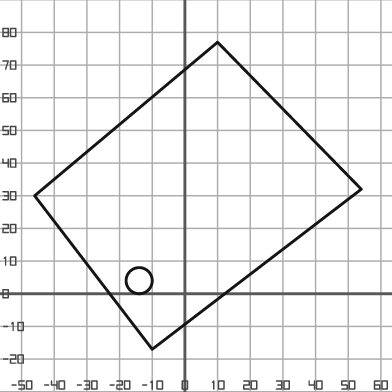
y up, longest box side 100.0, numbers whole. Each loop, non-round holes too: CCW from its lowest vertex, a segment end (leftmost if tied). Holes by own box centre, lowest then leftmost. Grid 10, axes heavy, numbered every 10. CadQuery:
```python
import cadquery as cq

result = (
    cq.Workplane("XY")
    .moveTo(-10.0, -17.0)
    .lineTo(54.0, 32.0)
    .lineTo(10.0, 77.0)
    .lineTo(-46.0, 30.0)
    .close()
    .moveTo(-14.0, 4.0)
    .circle(4.0)
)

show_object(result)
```